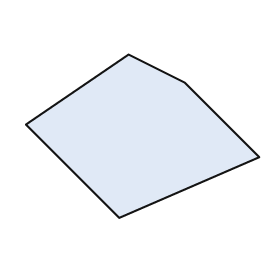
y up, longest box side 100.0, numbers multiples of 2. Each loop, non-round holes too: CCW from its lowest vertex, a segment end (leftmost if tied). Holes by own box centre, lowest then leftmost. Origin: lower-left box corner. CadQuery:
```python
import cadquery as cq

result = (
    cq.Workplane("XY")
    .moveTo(40.0, 0.0)
    .lineTo(100.0, 26.0)
    .lineTo(68.0, 58.0)
    .lineTo(44.0, 70.0)
    .lineTo(0.0, 40.0)
    .close()
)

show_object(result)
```